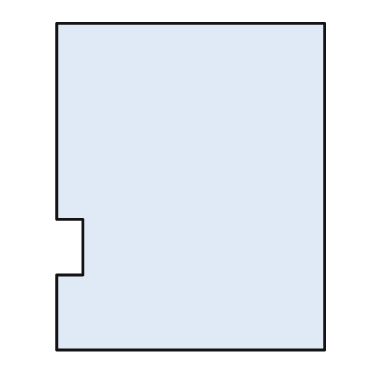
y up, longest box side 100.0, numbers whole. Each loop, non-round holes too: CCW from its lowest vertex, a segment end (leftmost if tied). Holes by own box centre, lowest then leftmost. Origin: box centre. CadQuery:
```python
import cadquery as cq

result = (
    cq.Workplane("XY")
    .moveTo(-41.0, -50.0)
    .lineTo(41.0, -50.0)
    .lineTo(41.0, 50.0)
    .lineTo(-41.0, 50.0)
    .lineTo(-41.0, -10.0)
    .lineTo(-33.0, -10.0)
    .lineTo(-33.0, -27.0)
    .lineTo(-41.0, -27.0)
    .close()
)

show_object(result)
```